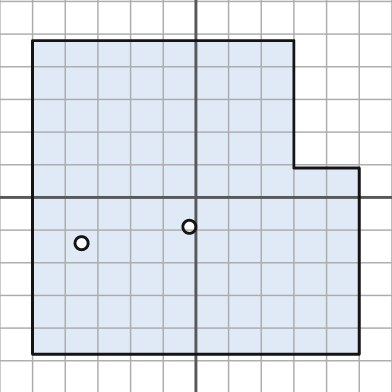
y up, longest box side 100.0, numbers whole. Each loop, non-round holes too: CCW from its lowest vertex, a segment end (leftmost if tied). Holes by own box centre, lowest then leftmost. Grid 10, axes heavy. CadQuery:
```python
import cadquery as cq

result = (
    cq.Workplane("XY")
    .moveTo(-50.0, -48.0)
    .lineTo(50.0, -48.0)
    .lineTo(50.0, 9.0)
    .lineTo(30.0, 9.0)
    .lineTo(30.0, 48.0)
    .lineTo(-50.0, 48.0)
    .close()
    .moveTo(-35.0, -14.0)
    .circle(2.0)
    .moveTo(-2.0, -9.0)
    .circle(2.0)
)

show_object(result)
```